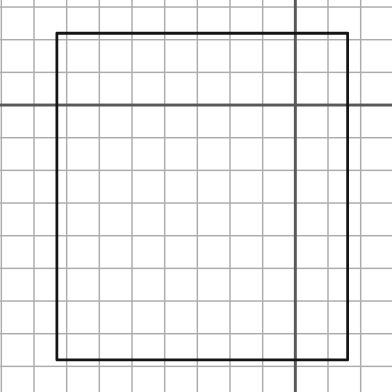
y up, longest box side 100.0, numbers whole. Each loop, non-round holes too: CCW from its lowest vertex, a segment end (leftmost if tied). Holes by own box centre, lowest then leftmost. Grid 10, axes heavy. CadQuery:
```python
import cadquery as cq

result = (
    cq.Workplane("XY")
    .moveTo(-73.0, -78.0)
    .lineTo(16.0, -78.0)
    .lineTo(16.0, 22.0)
    .lineTo(-73.0, 22.0)
    .close()
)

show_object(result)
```